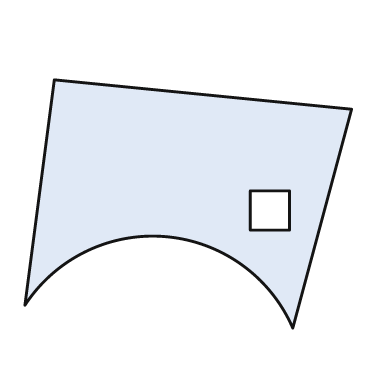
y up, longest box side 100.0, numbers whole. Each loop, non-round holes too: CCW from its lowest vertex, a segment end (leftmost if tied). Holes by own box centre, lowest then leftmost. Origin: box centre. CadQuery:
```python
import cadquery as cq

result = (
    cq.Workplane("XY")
    .moveTo(32.0, -38.0)
    .lineTo(50.0, 29.0)
    .lineTo(-41.0, 38.0)
    .lineTo(-50.0, -31.0)
    .threePointArc((-7.0, -10.0), (32.0, -38.0))
    .close()
    .moveTo(19.0, -8.0)
    .lineTo(31.0, -8.0)
    .lineTo(31.0, 4.0)
    .lineTo(19.0, 4.0)
    .close()
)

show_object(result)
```